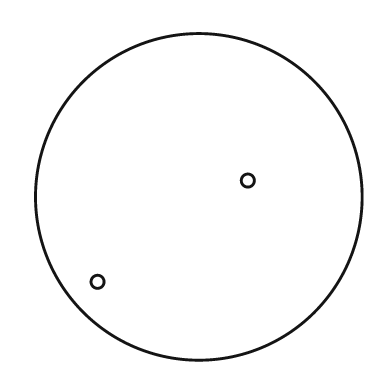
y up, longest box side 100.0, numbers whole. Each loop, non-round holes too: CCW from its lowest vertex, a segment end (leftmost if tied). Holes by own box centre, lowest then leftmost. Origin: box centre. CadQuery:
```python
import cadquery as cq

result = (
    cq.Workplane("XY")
    .moveTo(0.0, 0.0)
    .circle(50.0)
    .moveTo(-31.0, -26.0)
    .circle(2.0)
    .moveTo(15.0, 5.0)
    .circle(2.0)
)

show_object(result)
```